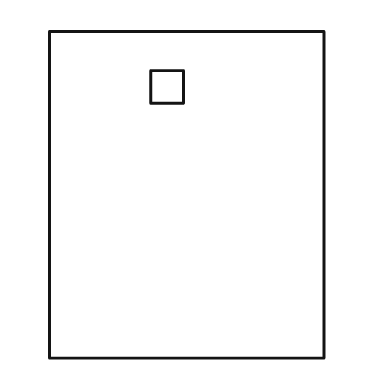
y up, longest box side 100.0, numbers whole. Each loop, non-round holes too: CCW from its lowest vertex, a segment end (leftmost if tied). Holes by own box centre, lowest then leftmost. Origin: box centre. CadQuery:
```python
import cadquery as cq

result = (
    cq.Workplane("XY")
    .moveTo(-42.0, -50.0)
    .lineTo(42.0, -50.0)
    .lineTo(42.0, 50.0)
    .lineTo(-42.0, 50.0)
    .close()
    .moveTo(-11.0, 28.0)
    .lineTo(-1.0, 28.0)
    .lineTo(-1.0, 38.0)
    .lineTo(-11.0, 38.0)
    .close()
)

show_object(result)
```